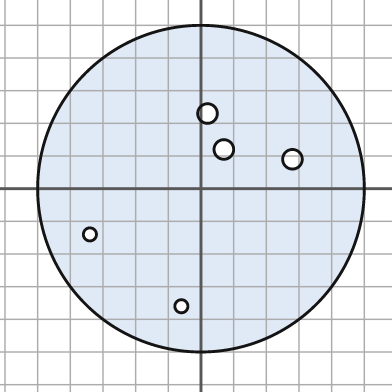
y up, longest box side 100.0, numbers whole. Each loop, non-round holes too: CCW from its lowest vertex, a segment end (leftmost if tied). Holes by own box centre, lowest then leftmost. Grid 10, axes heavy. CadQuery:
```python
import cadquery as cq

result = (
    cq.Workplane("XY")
    .moveTo(0.0, 0.0)
    .circle(50.0)
    .moveTo(-6.0, -36.0)
    .circle(2.0)
    .moveTo(-34.0, -14.0)
    .circle(2.0)
    .moveTo(28.0, 9.0)
    .circle(3.0)
    .moveTo(7.0, 12.0)
    .circle(3.0)
    .moveTo(2.0, 23.0)
    .circle(3.0)
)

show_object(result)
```